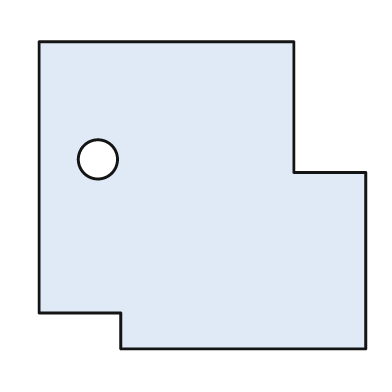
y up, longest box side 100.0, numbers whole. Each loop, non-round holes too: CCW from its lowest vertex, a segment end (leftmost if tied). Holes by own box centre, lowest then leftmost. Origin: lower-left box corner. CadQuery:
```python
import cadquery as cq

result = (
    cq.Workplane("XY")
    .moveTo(25.0, 0.0)
    .lineTo(100.0, 0.0)
    .lineTo(100.0, 54.0)
    .lineTo(78.0, 54.0)
    .lineTo(78.0, 94.0)
    .lineTo(0.0, 94.0)
    .lineTo(0.0, 11.0)
    .lineTo(25.0, 11.0)
    .close()
    .moveTo(18.0, 58.0)
    .circle(6.0)
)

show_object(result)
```